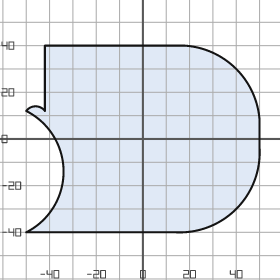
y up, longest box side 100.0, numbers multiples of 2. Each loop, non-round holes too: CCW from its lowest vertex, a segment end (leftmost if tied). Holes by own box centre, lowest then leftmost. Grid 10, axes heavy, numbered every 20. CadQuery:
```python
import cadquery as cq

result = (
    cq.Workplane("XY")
    .moveTo(-50.0, -40.0)
    .lineTo(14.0, -40.0)
    .threePointArc((40.0, -30.0), (50.0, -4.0))
    .lineTo(50.0, 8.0)
    .threePointArc((40.0, 30.0), (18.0, 40.0))
    .lineTo(-42.0, 40.0)
    .lineTo(-42.0, 12.0)
    .threePointArc((-46.0, 14.0), (-50.0, 12.0))
    .threePointArc((-34.0, -14.0), (-50.0, -40.0))
    .close()
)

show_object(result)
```